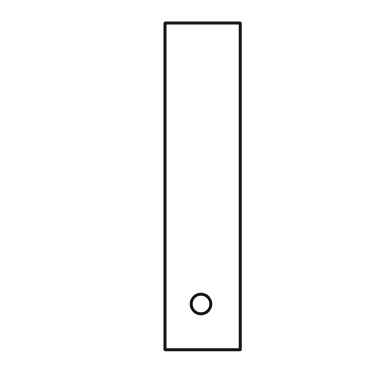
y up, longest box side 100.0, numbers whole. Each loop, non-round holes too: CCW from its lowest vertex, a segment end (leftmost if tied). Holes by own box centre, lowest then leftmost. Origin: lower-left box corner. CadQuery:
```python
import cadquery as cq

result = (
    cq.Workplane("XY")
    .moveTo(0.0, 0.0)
    .lineTo(23.0, 0.0)
    .lineTo(23.0, 100.0)
    .lineTo(0.0, 100.0)
    .close()
    .moveTo(11.0, 14.0)
    .circle(3.0)
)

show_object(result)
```